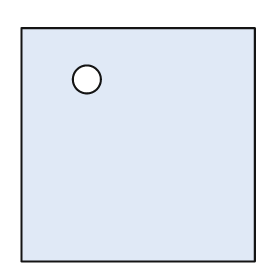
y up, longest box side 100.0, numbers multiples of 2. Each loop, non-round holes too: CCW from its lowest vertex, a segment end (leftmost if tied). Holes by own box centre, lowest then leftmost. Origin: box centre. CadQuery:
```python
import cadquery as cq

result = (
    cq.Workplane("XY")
    .moveTo(-50.0, -50.0)
    .lineTo(50.0, -50.0)
    .lineTo(50.0, 50.0)
    .lineTo(-50.0, 50.0)
    .close()
    .moveTo(-22.0, 28.0)
    .circle(6.0)
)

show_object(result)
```